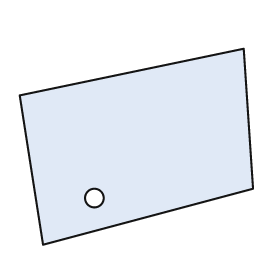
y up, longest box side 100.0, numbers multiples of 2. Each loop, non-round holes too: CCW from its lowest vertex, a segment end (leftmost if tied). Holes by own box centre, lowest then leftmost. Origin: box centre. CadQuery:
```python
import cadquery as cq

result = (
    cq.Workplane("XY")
    .moveTo(-40.0, -42.0)
    .lineTo(50.0, -18.0)
    .lineTo(46.0, 42.0)
    .lineTo(-50.0, 22.0)
    .close()
    .moveTo(-18.0, -22.0)
    .circle(4.0)
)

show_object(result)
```